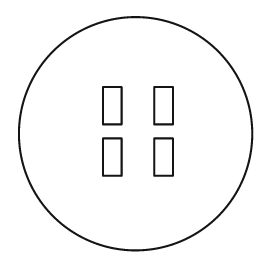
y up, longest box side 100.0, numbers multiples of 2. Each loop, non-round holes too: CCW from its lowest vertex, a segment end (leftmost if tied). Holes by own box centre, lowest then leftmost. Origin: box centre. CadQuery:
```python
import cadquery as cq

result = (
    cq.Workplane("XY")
    .moveTo(0.0, 0.0)
    .circle(50.0)
    .moveTo(-14.0, -18.0)
    .lineTo(-6.0, -18.0)
    .lineTo(-6.0, -2.0)
    .lineTo(-14.0, -2.0)
    .close()
    .moveTo(8.0, -18.0)
    .lineTo(16.0, -18.0)
    .lineTo(16.0, -2.0)
    .lineTo(8.0, -2.0)
    .close()
    .moveTo(-14.0, 4.0)
    .lineTo(-6.0, 4.0)
    .lineTo(-6.0, 20.0)
    .lineTo(-14.0, 20.0)
    .close()
    .moveTo(8.0, 4.0)
    .lineTo(16.0, 4.0)
    .lineTo(16.0, 20.0)
    .lineTo(8.0, 20.0)
    .close()
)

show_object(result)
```